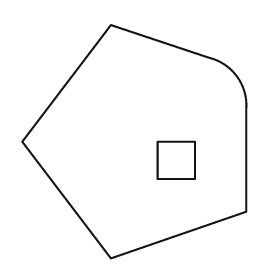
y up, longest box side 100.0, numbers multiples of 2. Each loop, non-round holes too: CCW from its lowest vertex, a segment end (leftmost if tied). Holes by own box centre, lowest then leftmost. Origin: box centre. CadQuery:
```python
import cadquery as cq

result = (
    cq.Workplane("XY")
    .moveTo(-10.0, -50.0)
    .lineTo(48.0, -30.0)
    .lineTo(48.0, 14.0)
    .threePointArc((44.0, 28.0), (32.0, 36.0))
    .lineTo(-10.0, 50.0)
    .lineTo(-48.0, 0.0)
    .close()
    .moveTo(10.0, -16.0)
    .lineTo(26.0, -16.0)
    .lineTo(26.0, 0.0)
    .lineTo(10.0, 0.0)
    .close()
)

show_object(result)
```